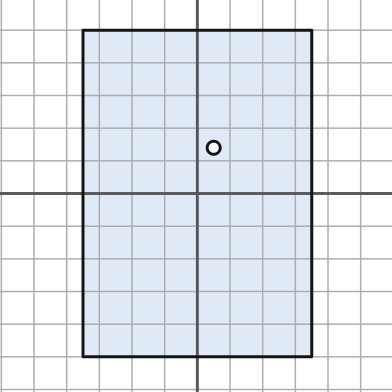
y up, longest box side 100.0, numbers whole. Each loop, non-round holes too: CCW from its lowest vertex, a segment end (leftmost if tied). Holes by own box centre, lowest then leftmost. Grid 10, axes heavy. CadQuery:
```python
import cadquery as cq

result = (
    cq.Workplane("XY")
    .moveTo(-35.0, -50.0)
    .lineTo(35.0, -50.0)
    .lineTo(35.0, 50.0)
    .lineTo(-35.0, 50.0)
    .close()
    .moveTo(5.0, 14.0)
    .circle(2.0)
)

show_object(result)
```